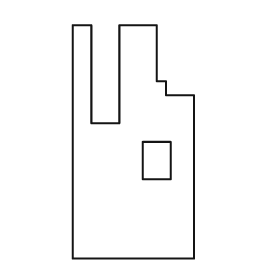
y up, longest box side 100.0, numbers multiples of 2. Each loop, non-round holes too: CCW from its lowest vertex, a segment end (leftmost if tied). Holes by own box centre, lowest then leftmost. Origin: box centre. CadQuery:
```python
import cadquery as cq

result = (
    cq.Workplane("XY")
    .moveTo(-26.0, -50.0)
    .lineTo(26.0, -50.0)
    .lineTo(26.0, 20.0)
    .lineTo(14.0, 20.0)
    .lineTo(14.0, 26.0)
    .lineTo(10.0, 26.0)
    .lineTo(10.0, 50.0)
    .lineTo(-6.0, 50.0)
    .lineTo(-6.0, 8.0)
    .lineTo(-18.0, 8.0)
    .lineTo(-18.0, 50.0)
    .lineTo(-26.0, 50.0)
    .close()
    .moveTo(4.0, -16.0)
    .lineTo(16.0, -16.0)
    .lineTo(16.0, 0.0)
    .lineTo(4.0, 0.0)
    .close()
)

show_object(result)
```